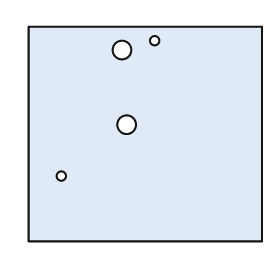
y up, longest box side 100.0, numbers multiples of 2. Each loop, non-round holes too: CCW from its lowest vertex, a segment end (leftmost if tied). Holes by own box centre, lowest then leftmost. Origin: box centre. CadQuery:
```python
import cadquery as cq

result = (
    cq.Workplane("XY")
    .moveTo(-50.0, -46.0)
    .lineTo(50.0, -46.0)
    .lineTo(50.0, 46.0)
    .lineTo(-50.0, 46.0)
    .close()
    .moveTo(-36.0, -18.0)
    .circle(2.0)
    .moveTo(-8.0, 4.0)
    .circle(4.0)
    .moveTo(-10.0, 36.0)
    .circle(4.0)
    .moveTo(4.0, 40.0)
    .circle(2.0)
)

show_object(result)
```